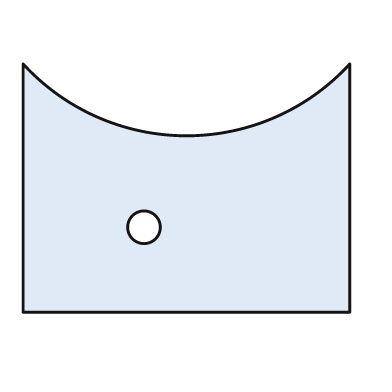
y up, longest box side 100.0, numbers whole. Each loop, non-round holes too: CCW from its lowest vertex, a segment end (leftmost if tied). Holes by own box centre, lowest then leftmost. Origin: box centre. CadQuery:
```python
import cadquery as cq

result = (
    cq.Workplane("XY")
    .moveTo(-50.0, -38.0)
    .lineTo(50.0, -38.0)
    .lineTo(50.0, 38.0)
    .threePointArc((0.0, 16.0), (-50.0, 38.0))
    .close()
    .moveTo(-13.0, -12.0)
    .circle(5.0)
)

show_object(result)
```